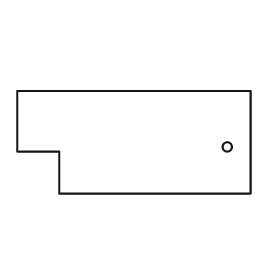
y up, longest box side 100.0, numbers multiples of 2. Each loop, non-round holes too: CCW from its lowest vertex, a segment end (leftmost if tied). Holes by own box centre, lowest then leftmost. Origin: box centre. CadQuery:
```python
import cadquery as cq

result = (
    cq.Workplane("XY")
    .moveTo(-32.0, -22.0)
    .lineTo(50.0, -22.0)
    .lineTo(50.0, 22.0)
    .lineTo(-50.0, 22.0)
    .lineTo(-50.0, -4.0)
    .lineTo(-32.0, -4.0)
    .close()
    .moveTo(40.0, -2.0)
    .circle(2.0)
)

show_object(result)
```